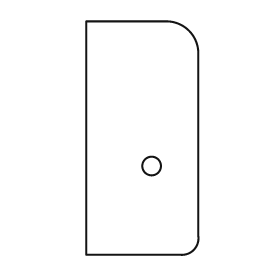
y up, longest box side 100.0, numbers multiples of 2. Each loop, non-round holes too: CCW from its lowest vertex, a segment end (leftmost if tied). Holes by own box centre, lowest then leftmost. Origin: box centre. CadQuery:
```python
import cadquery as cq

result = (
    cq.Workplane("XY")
    .moveTo(-24.0, -50.0)
    .lineTo(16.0, -50.0)
    .threePointArc((22.0, -48.0), (24.0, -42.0))
    .lineTo(24.0, 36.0)
    .threePointArc((20.0, 46.0), (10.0, 50.0))
    .lineTo(-24.0, 50.0)
    .close()
    .moveTo(4.0, -12.0)
    .circle(4.0)
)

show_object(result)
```